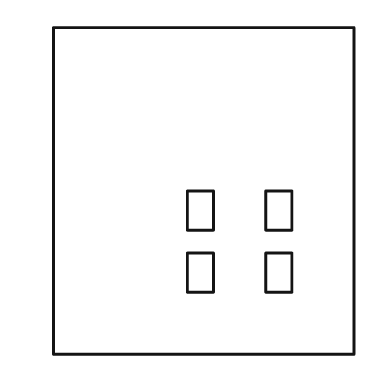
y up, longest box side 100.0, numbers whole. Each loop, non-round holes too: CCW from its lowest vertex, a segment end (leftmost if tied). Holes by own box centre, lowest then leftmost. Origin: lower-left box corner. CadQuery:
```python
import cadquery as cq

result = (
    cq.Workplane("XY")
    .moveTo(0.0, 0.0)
    .lineTo(92.0, 0.0)
    .lineTo(92.0, 100.0)
    .lineTo(0.0, 100.0)
    .close()
    .moveTo(41.0, 19.0)
    .lineTo(49.0, 19.0)
    .lineTo(49.0, 31.0)
    .lineTo(41.0, 31.0)
    .close()
    .moveTo(65.0, 19.0)
    .lineTo(73.0, 19.0)
    .lineTo(73.0, 31.0)
    .lineTo(65.0, 31.0)
    .close()
    .moveTo(41.0, 38.0)
    .lineTo(49.0, 38.0)
    .lineTo(49.0, 50.0)
    .lineTo(41.0, 50.0)
    .close()
    .moveTo(65.0, 38.0)
    .lineTo(73.0, 38.0)
    .lineTo(73.0, 50.0)
    .lineTo(65.0, 50.0)
    .close()
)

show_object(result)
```